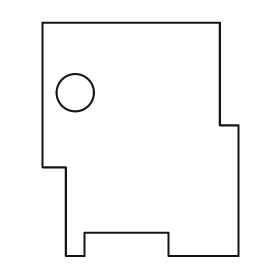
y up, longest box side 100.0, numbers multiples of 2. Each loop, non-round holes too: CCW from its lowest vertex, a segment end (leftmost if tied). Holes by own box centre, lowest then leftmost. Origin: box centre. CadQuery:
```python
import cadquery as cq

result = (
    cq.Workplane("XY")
    .moveTo(-32.0, -50.0)
    .lineTo(-24.0, -50.0)
    .lineTo(-24.0, -40.0)
    .lineTo(12.0, -40.0)
    .lineTo(12.0, -50.0)
    .lineTo(42.0, -50.0)
    .lineTo(42.0, 6.0)
    .lineTo(34.0, 6.0)
    .lineTo(34.0, 50.0)
    .lineTo(-42.0, 50.0)
    .lineTo(-42.0, -12.0)
    .lineTo(-32.0, -12.0)
    .close()
    .moveTo(-28.0, 20.0)
    .circle(8.0)
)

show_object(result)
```